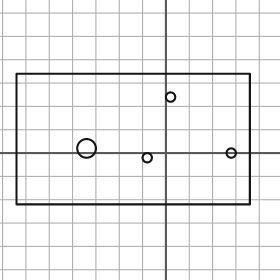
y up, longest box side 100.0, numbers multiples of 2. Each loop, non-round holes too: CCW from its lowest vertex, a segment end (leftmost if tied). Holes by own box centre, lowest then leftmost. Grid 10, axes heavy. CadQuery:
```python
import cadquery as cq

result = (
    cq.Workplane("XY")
    .moveTo(-64.0, -22.0)
    .lineTo(36.0, -22.0)
    .lineTo(36.0, 34.0)
    .lineTo(-64.0, 34.0)
    .close()
    .moveTo(-8.0, -2.0)
    .circle(2.0)
    .moveTo(28.0, 0.0)
    .circle(2.0)
    .moveTo(-34.0, 2.0)
    .circle(4.0)
    .moveTo(2.0, 24.0)
    .circle(2.0)
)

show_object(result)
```